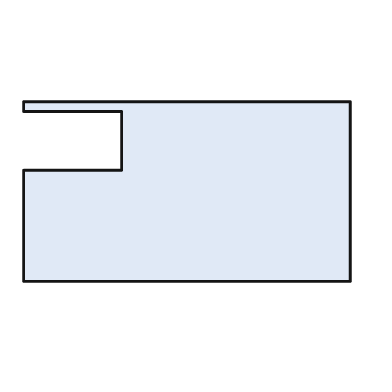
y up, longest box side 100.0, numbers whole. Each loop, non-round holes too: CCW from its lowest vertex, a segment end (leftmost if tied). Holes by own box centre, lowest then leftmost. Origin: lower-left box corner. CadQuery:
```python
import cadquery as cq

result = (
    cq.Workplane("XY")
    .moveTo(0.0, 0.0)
    .lineTo(100.0, 0.0)
    .lineTo(100.0, 55.0)
    .lineTo(0.0, 55.0)
    .lineTo(0.0, 52.0)
    .lineTo(30.0, 52.0)
    .lineTo(30.0, 34.0)
    .lineTo(0.0, 34.0)
    .close()
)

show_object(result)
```